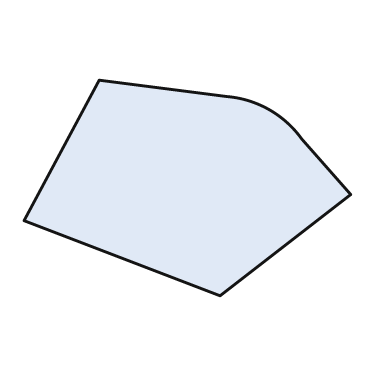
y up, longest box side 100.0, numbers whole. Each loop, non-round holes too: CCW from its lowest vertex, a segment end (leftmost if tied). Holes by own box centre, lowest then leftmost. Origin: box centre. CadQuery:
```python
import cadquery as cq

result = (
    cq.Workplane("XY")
    .moveTo(10.0, -33.0)
    .lineTo(50.0, -2.0)
    .lineTo(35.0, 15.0)
    .threePointArc((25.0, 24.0), (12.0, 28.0))
    .lineTo(-27.0, 33.0)
    .lineTo(-50.0, -10.0)
    .close()
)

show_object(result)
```